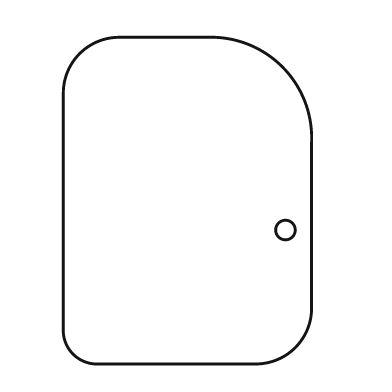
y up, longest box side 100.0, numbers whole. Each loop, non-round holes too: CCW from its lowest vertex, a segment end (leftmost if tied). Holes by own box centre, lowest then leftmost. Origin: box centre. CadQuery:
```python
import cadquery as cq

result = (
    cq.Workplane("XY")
    .moveTo(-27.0, -50.0)
    .lineTo(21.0, -50.0)
    .threePointArc((33.0, -45.0), (38.0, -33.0))
    .lineTo(38.0, 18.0)
    .threePointArc((29.0, 41.0), (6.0, 50.0))
    .lineTo(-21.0, 50.0)
    .threePointArc((-33.0, 45.0), (-38.0, 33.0))
    .lineTo(-38.0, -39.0)
    .threePointArc((-35.0, -47.0), (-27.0, -50.0))
    .close()
    .moveTo(30.0, -9.0)
    .circle(3.0)
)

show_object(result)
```